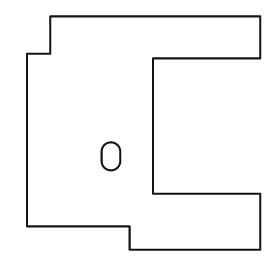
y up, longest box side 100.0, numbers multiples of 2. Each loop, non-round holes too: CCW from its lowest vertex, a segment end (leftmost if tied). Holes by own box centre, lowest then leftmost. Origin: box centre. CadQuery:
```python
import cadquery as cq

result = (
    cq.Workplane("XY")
    .moveTo(-6.0, -50.0)
    .lineTo(50.0, -50.0)
    .lineTo(50.0, -26.0)
    .lineTo(4.0, -26.0)
    .lineTo(4.0, 32.0)
    .lineTo(50.0, 32.0)
    .lineTo(50.0, 50.0)
    .lineTo(-40.0, 50.0)
    .lineTo(-40.0, 34.0)
    .lineTo(-50.0, 34.0)
    .lineTo(-50.0, -40.0)
    .lineTo(-6.0, -40.0)
    .close()
    .moveTo(-18.0, -12.0)
    .threePointArc((-14.0, -16.0), (-10.0, -12.0))
    .lineTo(-10.0, -8.0)
    .threePointArc((-14.0, -4.0), (-18.0, -8.0))
    .close()
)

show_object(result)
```